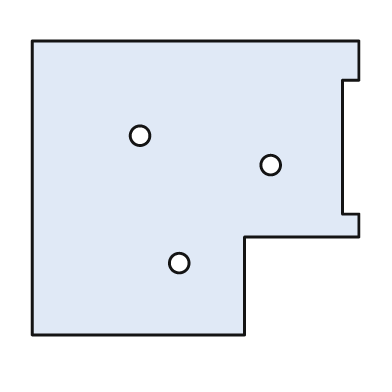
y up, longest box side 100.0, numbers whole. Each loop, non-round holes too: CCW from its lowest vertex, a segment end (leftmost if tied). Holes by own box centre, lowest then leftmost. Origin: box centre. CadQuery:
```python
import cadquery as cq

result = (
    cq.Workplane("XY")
    .moveTo(-50.0, -45.0)
    .lineTo(15.0, -45.0)
    .lineTo(15.0, -15.0)
    .lineTo(50.0, -15.0)
    .lineTo(50.0, -8.0)
    .lineTo(45.0, -8.0)
    .lineTo(45.0, 33.0)
    .lineTo(50.0, 33.0)
    .lineTo(50.0, 45.0)
    .lineTo(-50.0, 45.0)
    .close()
    .moveTo(-5.0, -23.0)
    .circle(3.0)
    .moveTo(23.0, 7.0)
    .circle(3.0)
    .moveTo(-17.0, 16.0)
    .circle(3.0)
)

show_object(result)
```